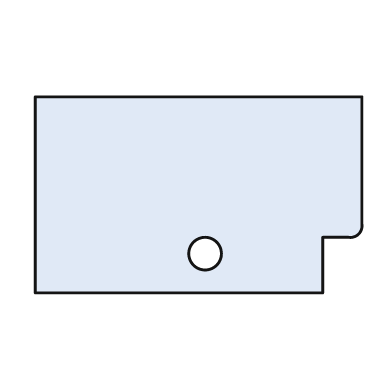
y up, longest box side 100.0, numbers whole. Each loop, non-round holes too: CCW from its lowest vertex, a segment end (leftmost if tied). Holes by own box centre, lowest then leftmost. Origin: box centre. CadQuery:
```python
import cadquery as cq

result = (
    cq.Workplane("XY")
    .moveTo(-50.0, -30.0)
    .lineTo(38.0, -30.0)
    .lineTo(38.0, -13.0)
    .lineTo(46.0, -13.0)
    .threePointArc((49.0, -12.0), (50.0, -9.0))
    .lineTo(50.0, 30.0)
    .lineTo(-50.0, 30.0)
    .close()
    .moveTo(2.0, -18.0)
    .circle(5.0)
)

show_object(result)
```